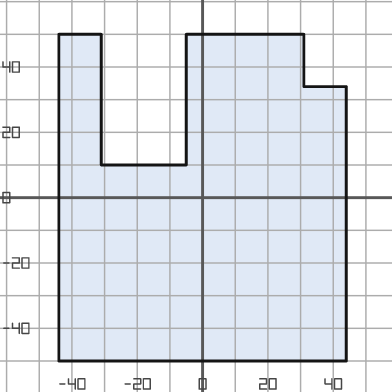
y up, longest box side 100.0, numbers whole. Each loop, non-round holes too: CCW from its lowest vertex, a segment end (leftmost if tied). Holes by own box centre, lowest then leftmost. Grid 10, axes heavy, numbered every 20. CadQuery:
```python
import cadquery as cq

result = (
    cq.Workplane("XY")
    .moveTo(-44.0, -50.0)
    .lineTo(44.0, -50.0)
    .lineTo(44.0, 34.0)
    .lineTo(31.0, 34.0)
    .lineTo(31.0, 50.0)
    .lineTo(-5.0, 50.0)
    .lineTo(-5.0, 10.0)
    .lineTo(-31.0, 10.0)
    .lineTo(-31.0, 50.0)
    .lineTo(-44.0, 50.0)
    .close()
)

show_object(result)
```